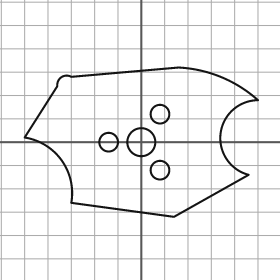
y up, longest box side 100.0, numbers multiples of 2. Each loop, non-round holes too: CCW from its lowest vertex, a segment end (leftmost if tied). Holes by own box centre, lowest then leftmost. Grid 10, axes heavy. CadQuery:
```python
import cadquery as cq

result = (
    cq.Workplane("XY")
    .moveTo(14.0, -32.0)
    .lineTo(46.0, -14.0)
    .threePointArc((34.0, 4.0), (50.0, 18.0))
    .threePointArc((34.0, 28.0), (16.0, 32.0))
    .lineTo(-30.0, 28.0)
    .threePointArc((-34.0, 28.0), (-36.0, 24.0))
    .lineTo(-50.0, 2.0)
    .threePointArc((-34.0, -8.0), (-30.0, -26.0))
    .close()
    .moveTo(8.0, -12.0)
    .circle(4.0)
    .moveTo(-14.0, 0.0)
    .circle(4.0)
    .moveTo(0.0, 0.0)
    .circle(6.0)
    .moveTo(8.0, 12.0)
    .circle(4.0)
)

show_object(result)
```